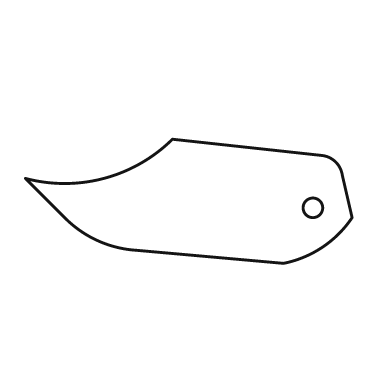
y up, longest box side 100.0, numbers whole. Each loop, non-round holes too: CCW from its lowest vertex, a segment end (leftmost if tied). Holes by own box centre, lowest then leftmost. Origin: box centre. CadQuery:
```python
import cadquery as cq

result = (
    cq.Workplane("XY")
    .moveTo(29.0, -19.0)
    .threePointArc((41.0, -14.0), (50.0, -5.0))
    .lineTo(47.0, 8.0)
    .threePointArc((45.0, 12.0), (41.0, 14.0))
    .lineTo(-5.0, 19.0)
    .threePointArc((-26.0, 7.0), (-50.0, 7.0))
    .lineTo(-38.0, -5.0)
    .threePointArc((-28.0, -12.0), (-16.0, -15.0))
    .close()
    .moveTo(38.0, -2.0)
    .circle(3.0)
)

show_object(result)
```